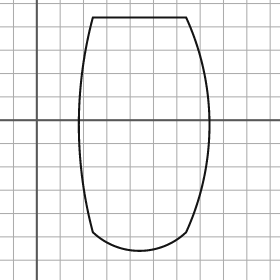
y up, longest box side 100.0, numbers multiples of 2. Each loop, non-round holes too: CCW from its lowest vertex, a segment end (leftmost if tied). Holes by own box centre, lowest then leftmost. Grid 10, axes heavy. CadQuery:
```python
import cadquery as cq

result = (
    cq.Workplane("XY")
    .moveTo(24.0, -48.0)
    .threePointArc((44.0, -56.0), (64.0, -48.0))
    .threePointArc((74.0, -2.0), (64.0, 44.0))
    .lineTo(24.0, 44.0)
    .threePointArc((18.0, -2.0), (24.0, -48.0))
    .close()
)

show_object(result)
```